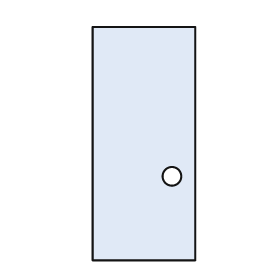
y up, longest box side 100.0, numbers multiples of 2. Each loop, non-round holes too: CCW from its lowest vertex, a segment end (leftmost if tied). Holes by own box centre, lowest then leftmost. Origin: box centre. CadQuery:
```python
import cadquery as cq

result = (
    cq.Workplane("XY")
    .moveTo(-22.0, -50.0)
    .lineTo(22.0, -50.0)
    .lineTo(22.0, 50.0)
    .lineTo(-22.0, 50.0)
    .close()
    .moveTo(12.0, -14.0)
    .circle(4.0)
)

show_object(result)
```